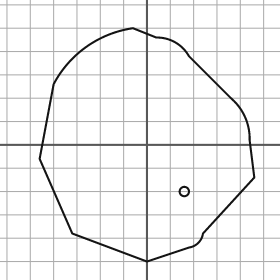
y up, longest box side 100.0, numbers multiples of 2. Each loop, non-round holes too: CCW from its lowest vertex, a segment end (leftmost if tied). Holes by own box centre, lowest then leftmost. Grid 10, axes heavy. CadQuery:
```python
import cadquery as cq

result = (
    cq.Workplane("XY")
    .moveTo(0.0, -50.0)
    .lineTo(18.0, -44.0)
    .threePointArc((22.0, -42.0), (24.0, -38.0))
    .lineTo(46.0, -14.0)
    .lineTo(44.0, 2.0)
    .threePointArc((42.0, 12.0), (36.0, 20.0))
    .lineTo(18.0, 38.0)
    .threePointArc((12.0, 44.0), (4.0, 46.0))
    .lineTo(-6.0, 50.0)
    .threePointArc((-26.0, 42.0), (-40.0, 26.0))
    .lineTo(-46.0, -6.0)
    .lineTo(-32.0, -38.0)
    .close()
    .moveTo(16.0, -20.0)
    .circle(2.0)
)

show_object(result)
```